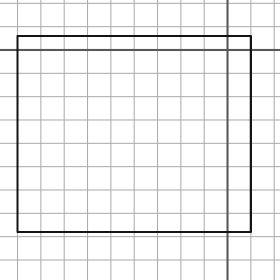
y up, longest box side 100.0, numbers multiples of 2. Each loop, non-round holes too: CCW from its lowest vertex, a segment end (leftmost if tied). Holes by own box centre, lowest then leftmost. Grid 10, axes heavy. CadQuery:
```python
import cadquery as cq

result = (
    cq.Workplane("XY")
    .moveTo(-90.0, -78.0)
    .lineTo(10.0, -78.0)
    .lineTo(10.0, 6.0)
    .lineTo(-90.0, 6.0)
    .close()
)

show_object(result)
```